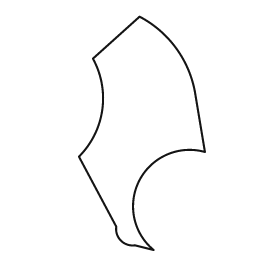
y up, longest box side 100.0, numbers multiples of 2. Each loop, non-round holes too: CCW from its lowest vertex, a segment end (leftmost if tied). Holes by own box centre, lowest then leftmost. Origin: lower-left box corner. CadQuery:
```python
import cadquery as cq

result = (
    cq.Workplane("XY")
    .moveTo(32.0, 0.0)
    .threePointArc((26.0, 30.0), (54.0, 42.0))
    .lineTo(50.0, 66.0)
    .threePointArc((42.0, 86.0), (26.0, 100.0))
    .lineTo(6.0, 82.0)
    .threePointArc((10.0, 60.0), (0.0, 40.0))
    .lineTo(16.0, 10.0)
    .threePointArc((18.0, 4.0), (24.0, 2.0))
    .close()
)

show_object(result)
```